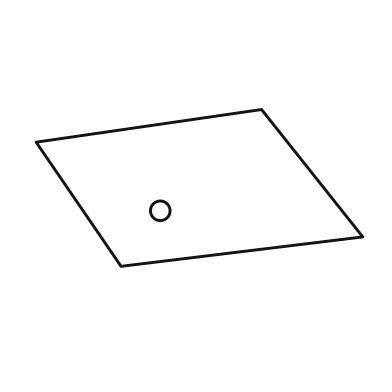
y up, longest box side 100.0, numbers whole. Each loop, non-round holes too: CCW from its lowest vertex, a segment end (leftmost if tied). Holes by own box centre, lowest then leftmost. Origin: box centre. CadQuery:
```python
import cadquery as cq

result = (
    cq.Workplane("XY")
    .moveTo(-24.0, -24.0)
    .lineTo(50.0, -15.0)
    .lineTo(19.0, 24.0)
    .lineTo(-50.0, 14.0)
    .close()
    .moveTo(-12.0, -7.0)
    .circle(3.0)
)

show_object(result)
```